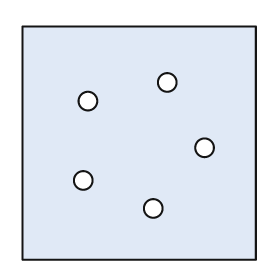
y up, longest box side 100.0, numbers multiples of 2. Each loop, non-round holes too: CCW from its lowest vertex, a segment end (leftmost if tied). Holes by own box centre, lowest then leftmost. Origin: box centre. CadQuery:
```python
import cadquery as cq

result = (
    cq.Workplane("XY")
    .moveTo(-50.0, -50.0)
    .lineTo(50.0, -50.0)
    .lineTo(50.0, 50.0)
    .lineTo(-50.0, 50.0)
    .close()
    .moveTo(6.0, -28.0)
    .circle(4.0)
    .moveTo(-24.0, -16.0)
    .circle(4.0)
    .moveTo(28.0, -2.0)
    .circle(4.0)
    .moveTo(-22.0, 18.0)
    .circle(4.0)
    .moveTo(12.0, 26.0)
    .circle(4.0)
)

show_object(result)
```